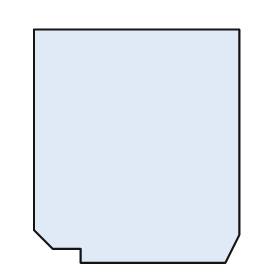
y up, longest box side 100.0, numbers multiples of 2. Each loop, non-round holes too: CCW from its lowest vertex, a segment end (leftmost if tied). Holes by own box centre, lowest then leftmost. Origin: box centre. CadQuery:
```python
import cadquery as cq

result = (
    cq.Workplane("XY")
    .moveTo(-24.0, -50.0)
    .lineTo(38.0, -50.0)
    .lineTo(44.0, -38.0)
    .lineTo(44.0, 50.0)
    .lineTo(-44.0, 50.0)
    .lineTo(-44.0, -36.0)
    .lineTo(-36.0, -44.0)
    .lineTo(-24.0, -44.0)
    .close()
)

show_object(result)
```